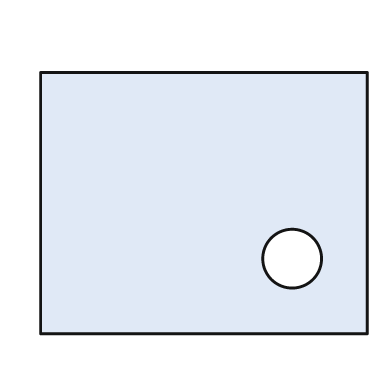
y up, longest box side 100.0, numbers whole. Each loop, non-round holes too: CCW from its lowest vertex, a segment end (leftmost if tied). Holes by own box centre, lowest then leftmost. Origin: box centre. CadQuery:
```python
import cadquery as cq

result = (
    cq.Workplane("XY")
    .moveTo(-50.0, -40.0)
    .lineTo(50.0, -40.0)
    .lineTo(50.0, 40.0)
    .lineTo(-50.0, 40.0)
    .close()
    .moveTo(27.0, -17.0)
    .circle(9.0)
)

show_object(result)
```